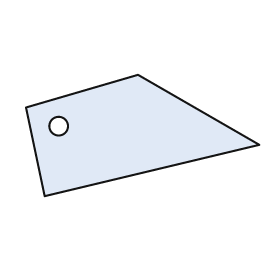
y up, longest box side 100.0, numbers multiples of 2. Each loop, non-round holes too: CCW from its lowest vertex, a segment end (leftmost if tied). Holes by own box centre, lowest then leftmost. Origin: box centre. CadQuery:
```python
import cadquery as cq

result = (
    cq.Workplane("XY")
    .moveTo(-42.0, -26.0)
    .lineTo(50.0, -4.0)
    .lineTo(-2.0, 26.0)
    .lineTo(-50.0, 12.0)
    .close()
    .moveTo(-36.0, 4.0)
    .circle(4.0)
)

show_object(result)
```